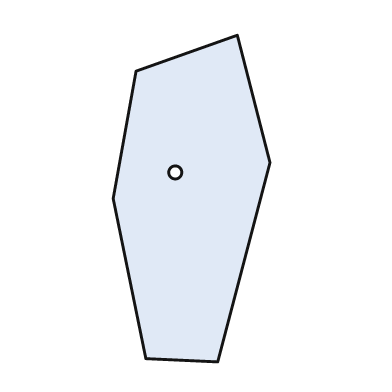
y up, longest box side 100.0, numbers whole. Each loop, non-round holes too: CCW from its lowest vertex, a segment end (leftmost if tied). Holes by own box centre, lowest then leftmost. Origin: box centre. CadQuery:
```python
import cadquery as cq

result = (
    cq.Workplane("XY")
    .moveTo(8.0, -50.0)
    .lineTo(24.0, 11.0)
    .lineTo(14.0, 50.0)
    .lineTo(-17.0, 39.0)
    .lineTo(-24.0, 0.0)
    .lineTo(-14.0, -49.0)
    .close()
    .moveTo(-5.0, 8.0)
    .circle(2.0)
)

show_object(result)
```